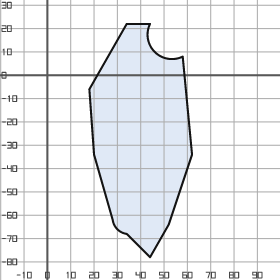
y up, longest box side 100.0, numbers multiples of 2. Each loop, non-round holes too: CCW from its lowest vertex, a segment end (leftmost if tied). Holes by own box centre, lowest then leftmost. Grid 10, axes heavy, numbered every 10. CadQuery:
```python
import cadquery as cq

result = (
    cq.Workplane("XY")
    .moveTo(44.0, -78.0)
    .lineTo(52.0, -64.0)
    .lineTo(62.0, -34.0)
    .lineTo(58.0, 8.0)
    .threePointArc((46.0, 10.0), (44.0, 22.0))
    .lineTo(34.0, 22.0)
    .lineTo(18.0, -6.0)
    .lineTo(20.0, -34.0)
    .lineTo(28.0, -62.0)
    .threePointArc((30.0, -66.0), (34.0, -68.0))
    .close()
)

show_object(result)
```